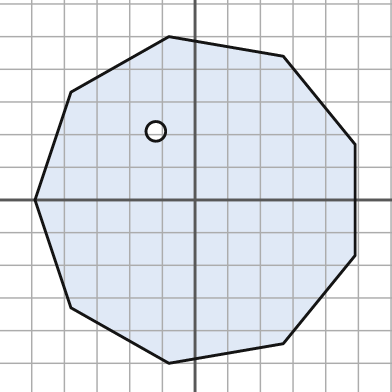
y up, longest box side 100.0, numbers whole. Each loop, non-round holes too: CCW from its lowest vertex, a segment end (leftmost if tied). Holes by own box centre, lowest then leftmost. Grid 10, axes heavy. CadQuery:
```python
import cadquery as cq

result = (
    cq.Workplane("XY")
    .moveTo(-8.0, -50.0)
    .lineTo(27.0, -44.0)
    .lineTo(49.0, -17.0)
    .lineTo(49.0, 17.0)
    .lineTo(27.0, 44.0)
    .lineTo(-8.0, 50.0)
    .lineTo(-38.0, 33.0)
    .lineTo(-49.0, 0.0)
    .lineTo(-38.0, -33.0)
    .close()
    .moveTo(-12.0, 21.0)
    .circle(3.0)
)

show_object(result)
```